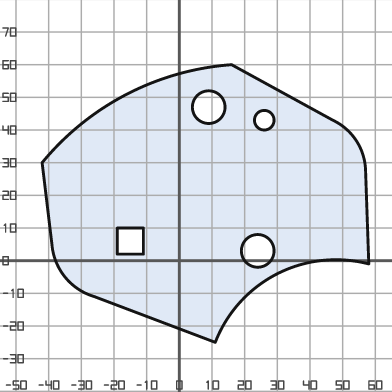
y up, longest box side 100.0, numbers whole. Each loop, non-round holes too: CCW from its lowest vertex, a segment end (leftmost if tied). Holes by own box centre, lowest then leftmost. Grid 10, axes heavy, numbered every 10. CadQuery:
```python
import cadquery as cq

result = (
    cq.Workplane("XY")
    .moveTo(11.0, -25.0)
    .threePointArc((30.0, -4.0), (58.0, -1.0))
    .lineTo(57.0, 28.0)
    .threePointArc((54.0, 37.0), (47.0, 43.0))
    .lineTo(16.0, 60.0)
    .threePointArc((-16.0, 51.0), (-42.0, 30.0))
    .lineTo(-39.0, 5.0)
    .threePointArc((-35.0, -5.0), (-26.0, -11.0))
    .close()
    .moveTo(24.0, 3.0)
    .circle(5.0)
    .moveTo(-19.0, 2.0)
    .lineTo(-11.0, 2.0)
    .lineTo(-11.0, 10.0)
    .lineTo(-19.0, 10.0)
    .close()
    .moveTo(26.0, 43.0)
    .circle(3.0)
    .moveTo(9.0, 47.0)
    .circle(5.0)
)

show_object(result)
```